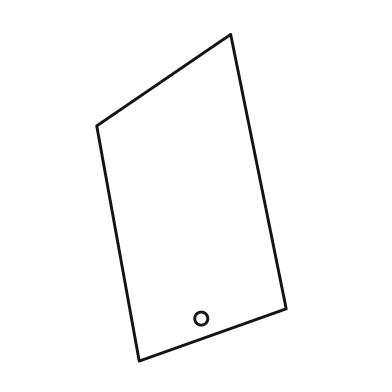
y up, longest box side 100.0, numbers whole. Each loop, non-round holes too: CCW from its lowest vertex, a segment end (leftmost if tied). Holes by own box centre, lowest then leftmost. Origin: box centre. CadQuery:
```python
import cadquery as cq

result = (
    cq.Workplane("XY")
    .moveTo(-16.0, -50.0)
    .lineTo(29.0, -34.0)
    .lineTo(12.0, 50.0)
    .lineTo(-29.0, 22.0)
    .close()
    .moveTo(3.0, -37.0)
    .circle(2.0)
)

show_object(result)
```